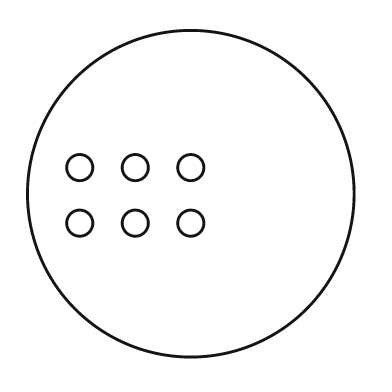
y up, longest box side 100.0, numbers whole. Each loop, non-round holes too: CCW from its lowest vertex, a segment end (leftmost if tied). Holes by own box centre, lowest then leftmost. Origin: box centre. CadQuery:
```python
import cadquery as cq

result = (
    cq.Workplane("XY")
    .moveTo(0.0, 0.0)
    .circle(50.0)
    .moveTo(-34.0, -9.0)
    .circle(4.0)
    .moveTo(-17.0, -9.0)
    .circle(4.0)
    .moveTo(0.0, -9.0)
    .circle(4.0)
    .moveTo(-34.0, 8.0)
    .circle(4.0)
    .moveTo(-17.0, 8.0)
    .circle(4.0)
    .moveTo(0.0, 8.0)
    .circle(4.0)
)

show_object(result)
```